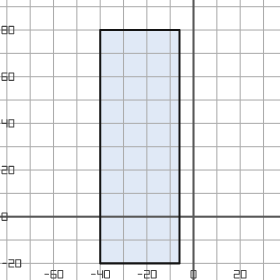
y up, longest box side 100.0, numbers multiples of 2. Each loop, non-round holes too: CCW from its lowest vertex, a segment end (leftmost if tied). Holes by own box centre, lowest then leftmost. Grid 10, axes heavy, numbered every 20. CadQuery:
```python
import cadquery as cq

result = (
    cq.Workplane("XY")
    .moveTo(-40.0, -20.0)
    .lineTo(-6.0, -20.0)
    .lineTo(-6.0, 80.0)
    .lineTo(-40.0, 80.0)
    .close()
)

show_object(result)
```